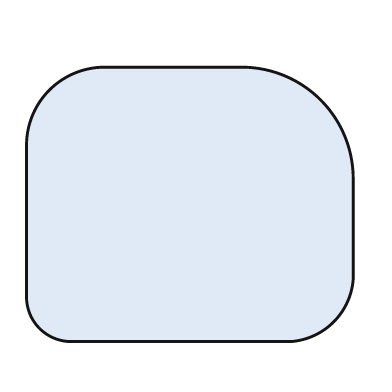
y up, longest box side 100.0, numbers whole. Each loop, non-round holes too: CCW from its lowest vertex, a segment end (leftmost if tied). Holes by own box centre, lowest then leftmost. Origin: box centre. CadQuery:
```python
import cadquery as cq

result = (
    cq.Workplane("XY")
    .moveTo(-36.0, -42.0)
    .lineTo(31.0, -42.0)
    .threePointArc((44.0, -36.0), (50.0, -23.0))
    .lineTo(50.0, 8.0)
    .threePointArc((40.0, 32.0), (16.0, 42.0))
    .lineTo(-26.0, 42.0)
    .threePointArc((-43.0, 35.0), (-50.0, 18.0))
    .lineTo(-50.0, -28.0)
    .threePointArc((-46.0, -38.0), (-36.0, -42.0))
    .close()
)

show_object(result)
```